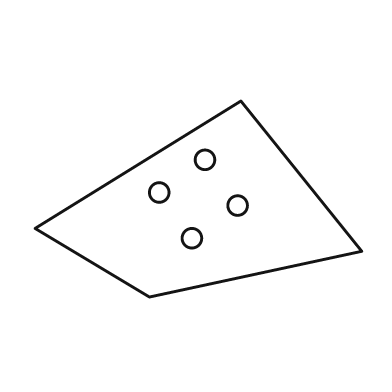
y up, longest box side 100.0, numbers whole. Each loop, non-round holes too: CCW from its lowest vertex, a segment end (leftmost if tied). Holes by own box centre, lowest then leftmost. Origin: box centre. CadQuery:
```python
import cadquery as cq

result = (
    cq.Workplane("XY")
    .moveTo(-15.0, -30.0)
    .lineTo(50.0, -16.0)
    .lineTo(13.0, 30.0)
    .lineTo(-50.0, -9.0)
    .close()
    .moveTo(-2.0, -12.0)
    .circle(3.0)
    .moveTo(12.0, -2.0)
    .circle(3.0)
    .moveTo(-12.0, 2.0)
    .circle(3.0)
    .moveTo(2.0, 12.0)
    .circle(3.0)
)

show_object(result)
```